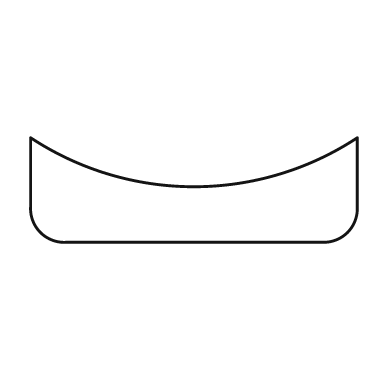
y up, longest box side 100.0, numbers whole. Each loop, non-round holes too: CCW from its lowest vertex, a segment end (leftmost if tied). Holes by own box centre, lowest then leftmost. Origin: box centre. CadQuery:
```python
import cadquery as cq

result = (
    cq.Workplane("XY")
    .moveTo(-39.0, -16.0)
    .lineTo(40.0, -16.0)
    .threePointArc((47.0, -13.0), (50.0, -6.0))
    .lineTo(50.0, 16.0)
    .threePointArc((0.0, 1.0), (-50.0, 16.0))
    .lineTo(-50.0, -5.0)
    .threePointArc((-47.0, -13.0), (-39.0, -16.0))
    .close()
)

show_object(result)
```